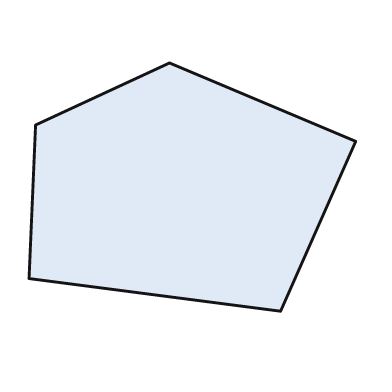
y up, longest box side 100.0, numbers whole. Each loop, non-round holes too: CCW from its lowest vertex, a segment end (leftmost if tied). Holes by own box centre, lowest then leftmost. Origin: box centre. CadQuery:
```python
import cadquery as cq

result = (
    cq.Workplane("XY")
    .moveTo(27.0, -38.0)
    .lineTo(50.0, 14.0)
    .lineTo(-7.0, 38.0)
    .lineTo(-48.0, 19.0)
    .lineTo(-50.0, -28.0)
    .close()
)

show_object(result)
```